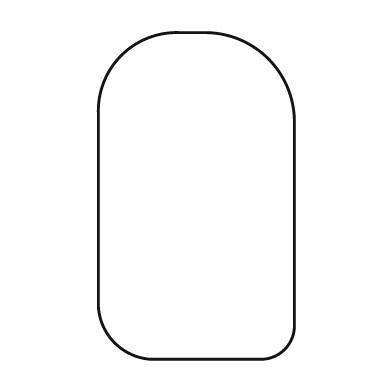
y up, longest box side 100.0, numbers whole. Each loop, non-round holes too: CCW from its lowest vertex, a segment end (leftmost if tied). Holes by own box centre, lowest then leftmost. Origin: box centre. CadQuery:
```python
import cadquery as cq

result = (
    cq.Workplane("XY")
    .moveTo(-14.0, -50.0)
    .lineTo(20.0, -50.0)
    .threePointArc((27.0, -47.0), (30.0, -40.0))
    .lineTo(30.0, 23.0)
    .threePointArc((22.0, 42.0), (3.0, 50.0))
    .lineTo(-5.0, 50.0)
    .threePointArc((-23.0, 43.0), (-30.0, 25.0))
    .lineTo(-30.0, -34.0)
    .threePointArc((-25.0, -45.0), (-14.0, -50.0))
    .close()
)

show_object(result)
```